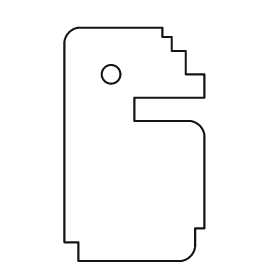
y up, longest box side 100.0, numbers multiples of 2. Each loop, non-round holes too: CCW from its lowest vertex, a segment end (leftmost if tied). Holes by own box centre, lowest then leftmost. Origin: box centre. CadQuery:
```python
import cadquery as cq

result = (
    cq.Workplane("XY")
    .moveTo(-24.0, -50.0)
    .lineTo(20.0, -50.0)
    .threePointArc((24.0, -48.0), (26.0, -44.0))
    .lineTo(26.0, -36.0)
    .lineTo(30.0, -36.0)
    .lineTo(30.0, 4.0)
    .threePointArc((28.0, 8.0), (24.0, 10.0))
    .lineTo(0.0, 10.0)
    .lineTo(0.0, 20.0)
    .lineTo(30.0, 20.0)
    .lineTo(30.0, 30.0)
    .lineTo(22.0, 30.0)
    .lineTo(22.0, 40.0)
    .lineTo(16.0, 40.0)
    .lineTo(16.0, 46.0)
    .lineTo(12.0, 46.0)
    .lineTo(12.0, 50.0)
    .lineTo(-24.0, 50.0)
    .threePointArc((-28.0, 48.0), (-30.0, 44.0))
    .lineTo(-30.0, -42.0)
    .lineTo(-24.0, -42.0)
    .close()
    .moveTo(-10.0, 30.0)
    .circle(4.0)
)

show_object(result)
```